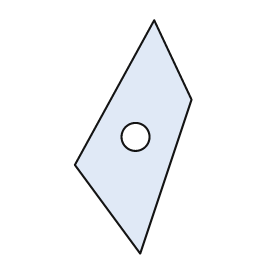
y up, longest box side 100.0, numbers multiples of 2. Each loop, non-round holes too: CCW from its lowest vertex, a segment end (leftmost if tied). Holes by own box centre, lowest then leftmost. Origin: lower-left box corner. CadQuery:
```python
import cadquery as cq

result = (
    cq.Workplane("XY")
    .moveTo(28.0, 0.0)
    .lineTo(50.0, 66.0)
    .lineTo(34.0, 100.0)
    .lineTo(0.0, 38.0)
    .close()
    .moveTo(26.0, 50.0)
    .circle(6.0)
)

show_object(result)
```